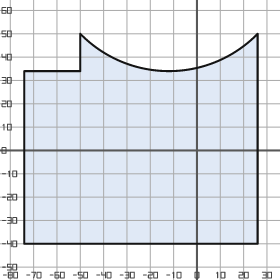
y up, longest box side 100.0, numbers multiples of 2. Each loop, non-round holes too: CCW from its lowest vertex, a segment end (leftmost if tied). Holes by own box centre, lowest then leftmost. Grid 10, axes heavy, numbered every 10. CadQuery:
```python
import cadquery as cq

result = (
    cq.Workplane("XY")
    .moveTo(-74.0, -40.0)
    .lineTo(26.0, -40.0)
    .lineTo(26.0, 50.0)
    .threePointArc((-12.0, 34.0), (-50.0, 50.0))
    .lineTo(-50.0, 34.0)
    .lineTo(-74.0, 34.0)
    .close()
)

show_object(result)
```